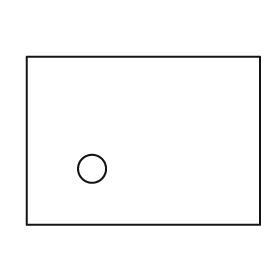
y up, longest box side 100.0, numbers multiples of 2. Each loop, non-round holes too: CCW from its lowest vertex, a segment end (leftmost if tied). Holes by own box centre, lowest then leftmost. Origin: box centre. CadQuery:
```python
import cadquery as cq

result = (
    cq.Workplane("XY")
    .moveTo(-50.0, -36.0)
    .lineTo(50.0, -36.0)
    .lineTo(50.0, 36.0)
    .lineTo(-50.0, 36.0)
    .close()
    .moveTo(-22.0, -12.0)
    .circle(6.0)
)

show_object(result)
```